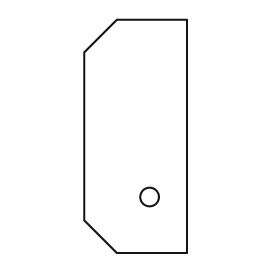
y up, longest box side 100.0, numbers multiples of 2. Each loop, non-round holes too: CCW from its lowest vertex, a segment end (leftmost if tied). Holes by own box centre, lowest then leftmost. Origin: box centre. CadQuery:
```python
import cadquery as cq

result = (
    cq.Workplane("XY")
    .moveTo(-8.0, -50.0)
    .lineTo(22.0, -50.0)
    .lineTo(22.0, 50.0)
    .lineTo(-8.0, 50.0)
    .lineTo(-22.0, 36.0)
    .lineTo(-22.0, -36.0)
    .close()
    .moveTo(6.0, -26.0)
    .circle(4.0)
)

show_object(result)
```